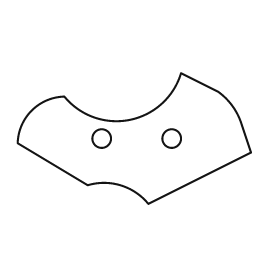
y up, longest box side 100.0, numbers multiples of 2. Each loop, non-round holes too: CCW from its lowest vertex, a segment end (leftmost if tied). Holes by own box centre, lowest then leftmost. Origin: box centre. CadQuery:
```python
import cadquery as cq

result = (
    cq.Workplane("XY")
    .moveTo(6.0, -28.0)
    .lineTo(50.0, -6.0)
    .lineTo(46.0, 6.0)
    .threePointArc((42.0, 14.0), (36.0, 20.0))
    .lineTo(20.0, 28.0)
    .threePointArc((-2.0, 8.0), (-30.0, 18.0))
    .threePointArc((-44.0, 12.0), (-50.0, -2.0))
    .lineTo(-20.0, -20.0)
    .threePointArc((-6.0, -20.0), (6.0, -28.0))
    .close()
    .moveTo(-14.0, 0.0)
    .circle(4.0)
    .moveTo(16.0, 0.0)
    .circle(4.0)
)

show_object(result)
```